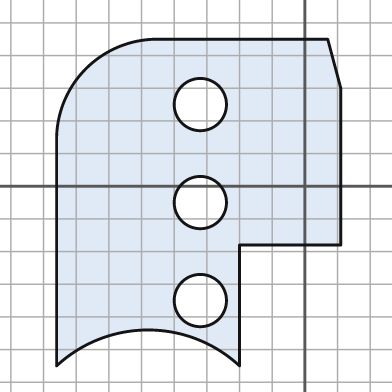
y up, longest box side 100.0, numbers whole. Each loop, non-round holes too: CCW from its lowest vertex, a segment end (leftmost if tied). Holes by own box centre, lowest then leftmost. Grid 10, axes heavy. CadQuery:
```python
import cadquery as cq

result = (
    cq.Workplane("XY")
    .moveTo(-76.0, -55.0)
    .threePointArc((-48.0, -44.0), (-20.0, -55.0))
    .lineTo(-20.0, -18.0)
    .lineTo(11.0, -18.0)
    .lineTo(11.0, 30.0)
    .lineTo(7.0, 45.0)
    .lineTo(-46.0, 45.0)
    .threePointArc((-67.0, 36.0), (-76.0, 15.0))
    .close()
    .moveTo(-32.0, -35.0)
    .circle(8.0)
    .moveTo(-32.0, -5.0)
    .circle(8.0)
    .moveTo(-32.0, 25.0)
    .circle(8.0)
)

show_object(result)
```